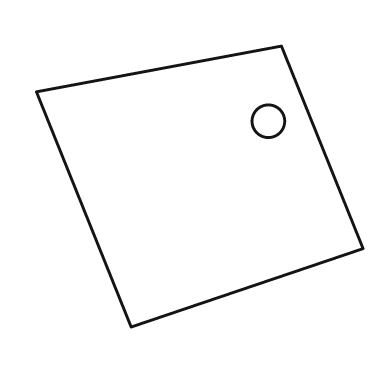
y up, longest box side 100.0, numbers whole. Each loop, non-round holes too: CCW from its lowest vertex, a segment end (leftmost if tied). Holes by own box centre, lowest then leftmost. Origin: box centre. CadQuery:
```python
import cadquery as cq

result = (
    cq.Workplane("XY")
    .moveTo(-21.0, -43.0)
    .lineTo(50.0, -19.0)
    .lineTo(25.0, 43.0)
    .lineTo(-50.0, 29.0)
    .close()
    .moveTo(21.0, 20.0)
    .circle(5.0)
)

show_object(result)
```